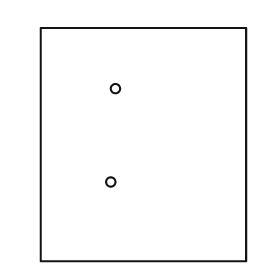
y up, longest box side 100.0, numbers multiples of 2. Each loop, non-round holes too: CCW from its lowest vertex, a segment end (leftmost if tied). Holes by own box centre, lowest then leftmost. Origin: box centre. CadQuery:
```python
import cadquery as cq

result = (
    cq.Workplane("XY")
    .moveTo(-44.0, -50.0)
    .lineTo(44.0, -50.0)
    .lineTo(44.0, 50.0)
    .lineTo(-44.0, 50.0)
    .close()
    .moveTo(-14.0, -16.0)
    .circle(2.0)
    .moveTo(-12.0, 24.0)
    .circle(2.0)
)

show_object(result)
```